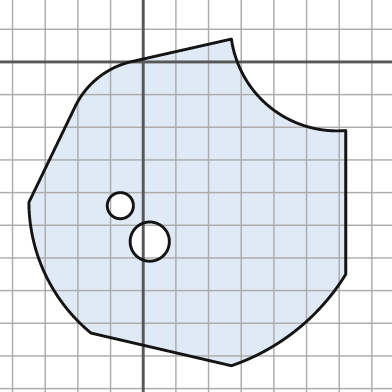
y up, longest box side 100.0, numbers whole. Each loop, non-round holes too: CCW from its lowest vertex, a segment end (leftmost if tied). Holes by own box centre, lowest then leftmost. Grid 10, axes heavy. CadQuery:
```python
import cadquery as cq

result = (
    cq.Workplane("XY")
    .moveTo(27.0, -93.0)
    .threePointArc((47.0, -82.0), (62.0, -65.0))
    .lineTo(62.0, -21.0)
    .threePointArc((39.0, -14.0), (27.0, 7.0))
    .lineTo(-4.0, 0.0)
    .threePointArc((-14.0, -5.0), (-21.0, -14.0))
    .lineTo(-35.0, -43.0)
    .threePointArc((-30.0, -65.0), (-16.0, -83.0))
    .close()
    .moveTo(2.0, -55.0)
    .circle(6.0)
    .moveTo(-7.0, -44.0)
    .circle(4.0)
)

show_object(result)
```